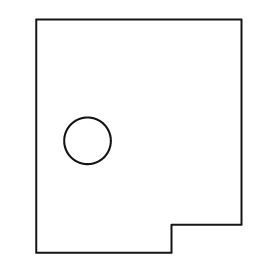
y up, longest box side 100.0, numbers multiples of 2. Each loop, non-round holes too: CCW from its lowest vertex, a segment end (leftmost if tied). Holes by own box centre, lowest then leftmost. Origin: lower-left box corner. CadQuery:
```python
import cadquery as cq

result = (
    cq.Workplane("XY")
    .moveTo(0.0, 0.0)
    .lineTo(58.0, 0.0)
    .lineTo(58.0, 12.0)
    .lineTo(88.0, 12.0)
    .lineTo(88.0, 100.0)
    .lineTo(0.0, 100.0)
    .close()
    .moveTo(22.0, 48.0)
    .circle(10.0)
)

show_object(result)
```